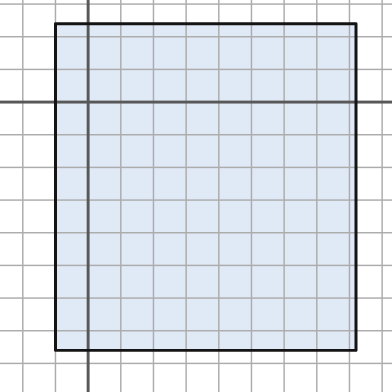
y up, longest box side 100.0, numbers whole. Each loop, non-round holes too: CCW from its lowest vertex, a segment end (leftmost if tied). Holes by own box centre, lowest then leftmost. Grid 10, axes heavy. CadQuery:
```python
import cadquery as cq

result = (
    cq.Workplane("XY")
    .moveTo(-10.0, -76.0)
    .lineTo(82.0, -76.0)
    .lineTo(82.0, 24.0)
    .lineTo(-10.0, 24.0)
    .close()
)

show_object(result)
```